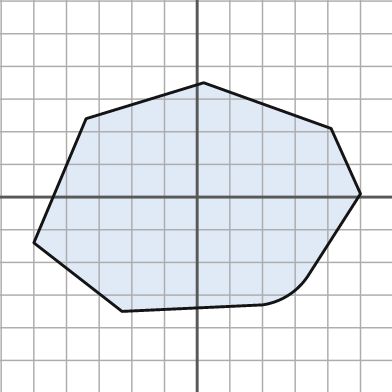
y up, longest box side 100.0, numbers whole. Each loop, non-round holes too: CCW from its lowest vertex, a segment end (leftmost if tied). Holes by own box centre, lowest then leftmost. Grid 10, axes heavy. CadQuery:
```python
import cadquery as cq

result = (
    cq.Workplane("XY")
    .moveTo(-23.0, -35.0)
    .lineTo(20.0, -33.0)
    .threePointArc((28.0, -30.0), (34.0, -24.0))
    .lineTo(50.0, 1.0)
    .lineTo(41.0, 21.0)
    .lineTo(2.0, 35.0)
    .lineTo(-34.0, 24.0)
    .lineTo(-50.0, -14.0)
    .close()
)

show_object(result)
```